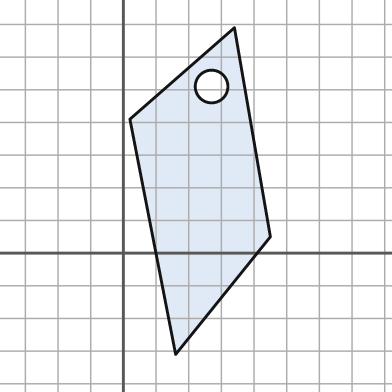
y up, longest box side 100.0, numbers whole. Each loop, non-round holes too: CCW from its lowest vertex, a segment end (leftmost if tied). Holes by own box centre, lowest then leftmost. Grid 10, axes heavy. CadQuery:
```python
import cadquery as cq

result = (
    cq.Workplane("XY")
    .moveTo(16.0, -31.0)
    .lineTo(45.0, 5.0)
    .lineTo(34.0, 69.0)
    .lineTo(2.0, 41.0)
    .close()
    .moveTo(27.0, 51.0)
    .circle(5.0)
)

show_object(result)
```